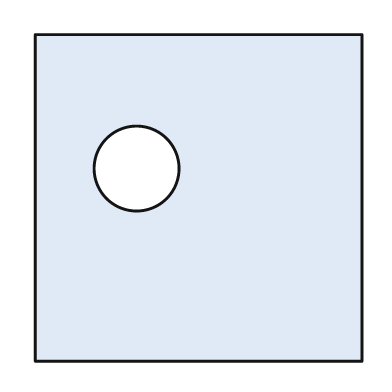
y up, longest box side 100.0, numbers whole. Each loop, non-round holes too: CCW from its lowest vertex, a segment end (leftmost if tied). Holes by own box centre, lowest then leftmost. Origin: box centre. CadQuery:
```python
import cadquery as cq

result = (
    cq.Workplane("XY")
    .moveTo(-50.0, -50.0)
    .lineTo(50.0, -50.0)
    .lineTo(50.0, 50.0)
    .lineTo(-50.0, 50.0)
    .close()
    .moveTo(-19.0, 9.0)
    .circle(13.0)
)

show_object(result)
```